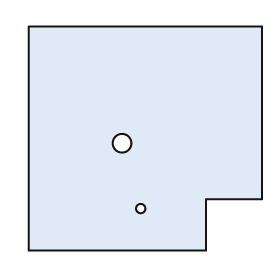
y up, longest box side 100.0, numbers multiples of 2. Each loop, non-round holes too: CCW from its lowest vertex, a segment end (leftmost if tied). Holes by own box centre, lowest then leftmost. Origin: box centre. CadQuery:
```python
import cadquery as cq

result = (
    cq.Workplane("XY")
    .moveTo(-50.0, -48.0)
    .lineTo(26.0, -48.0)
    .lineTo(26.0, -26.0)
    .lineTo(50.0, -26.0)
    .lineTo(50.0, 48.0)
    .lineTo(-50.0, 48.0)
    .close()
    .moveTo(-2.0, -30.0)
    .circle(2.0)
    .moveTo(-10.0, -2.0)
    .circle(4.0)
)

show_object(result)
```